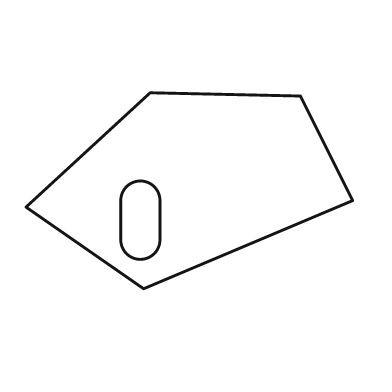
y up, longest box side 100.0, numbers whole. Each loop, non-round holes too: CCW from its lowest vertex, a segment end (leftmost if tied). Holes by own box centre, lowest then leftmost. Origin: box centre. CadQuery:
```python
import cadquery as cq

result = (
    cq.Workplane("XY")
    .moveTo(-14.0, -30.0)
    .lineTo(50.0, -3.0)
    .lineTo(34.0, 29.0)
    .lineTo(-12.0, 30.0)
    .lineTo(-50.0, -5.0)
    .close()
    .moveTo(-21.0, -15.0)
    .threePointArc((-15.0, -21.0), (-9.0, -15.0))
    .lineTo(-9.0, -3.0)
    .threePointArc((-15.0, 3.0), (-21.0, -3.0))
    .close()
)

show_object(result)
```